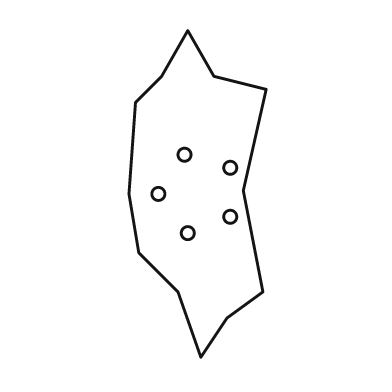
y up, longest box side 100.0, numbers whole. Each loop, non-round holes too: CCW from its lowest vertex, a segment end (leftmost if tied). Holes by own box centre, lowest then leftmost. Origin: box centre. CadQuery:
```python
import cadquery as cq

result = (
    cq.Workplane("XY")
    .moveTo(1.0, -50.0)
    .lineTo(9.0, -38.0)
    .lineTo(20.0, -30.0)
    .lineTo(14.0, 1.0)
    .lineTo(21.0, 32.0)
    .lineTo(5.0, 36.0)
    .lineTo(-3.0, 50.0)
    .lineTo(-11.0, 36.0)
    .lineTo(-19.0, 28.0)
    .lineTo(-21.0, 0.0)
    .lineTo(-18.0, -18.0)
    .lineTo(-6.0, -30.0)
    .close()
    .moveTo(-3.0, -12.0)
    .circle(2.0)
    .moveTo(10.0, -7.0)
    .circle(2.0)
    .moveTo(-12.0, 0.0)
    .circle(2.0)
    .moveTo(10.0, 8.0)
    .circle(2.0)
    .moveTo(-4.0, 12.0)
    .circle(2.0)
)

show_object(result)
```